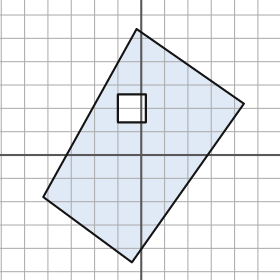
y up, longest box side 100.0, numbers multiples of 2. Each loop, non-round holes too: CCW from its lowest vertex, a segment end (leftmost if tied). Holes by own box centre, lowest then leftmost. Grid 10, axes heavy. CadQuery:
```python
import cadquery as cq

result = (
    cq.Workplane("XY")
    .moveTo(-4.0, -46.0)
    .lineTo(44.0, 22.0)
    .lineTo(-2.0, 54.0)
    .lineTo(-42.0, -18.0)
    .close()
    .moveTo(-10.0, 14.0)
    .lineTo(2.0, 14.0)
    .lineTo(2.0, 26.0)
    .lineTo(-10.0, 26.0)
    .close()
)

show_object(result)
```